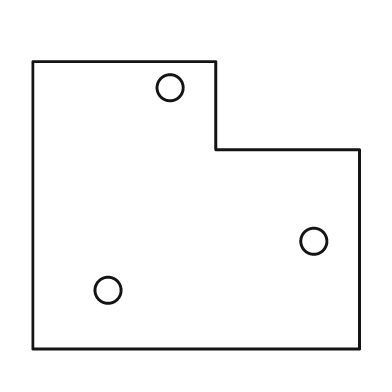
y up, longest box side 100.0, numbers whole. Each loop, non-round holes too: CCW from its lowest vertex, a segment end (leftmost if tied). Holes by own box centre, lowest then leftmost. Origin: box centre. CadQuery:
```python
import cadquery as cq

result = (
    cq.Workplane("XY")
    .moveTo(-50.0, -44.0)
    .lineTo(50.0, -44.0)
    .lineTo(50.0, 17.0)
    .lineTo(6.0, 17.0)
    .lineTo(6.0, 44.0)
    .lineTo(-50.0, 44.0)
    .close()
    .moveTo(-27.0, -26.0)
    .circle(4.0)
    .moveTo(36.0, -11.0)
    .circle(4.0)
    .moveTo(-8.0, 36.0)
    .circle(4.0)
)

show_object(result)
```